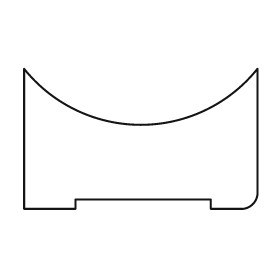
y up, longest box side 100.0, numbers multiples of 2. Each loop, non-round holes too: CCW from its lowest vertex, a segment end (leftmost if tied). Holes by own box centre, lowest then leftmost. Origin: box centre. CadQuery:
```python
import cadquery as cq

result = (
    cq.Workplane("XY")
    .moveTo(-50.0, -30.0)
    .lineTo(-28.0, -30.0)
    .lineTo(-28.0, -26.0)
    .lineTo(30.0, -26.0)
    .lineTo(30.0, -30.0)
    .lineTo(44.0, -30.0)
    .threePointArc((48.0, -28.0), (50.0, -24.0))
    .lineTo(50.0, 30.0)
    .threePointArc((0.0, 6.0), (-50.0, 30.0))
    .close()
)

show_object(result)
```